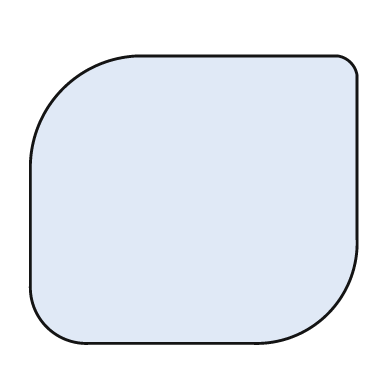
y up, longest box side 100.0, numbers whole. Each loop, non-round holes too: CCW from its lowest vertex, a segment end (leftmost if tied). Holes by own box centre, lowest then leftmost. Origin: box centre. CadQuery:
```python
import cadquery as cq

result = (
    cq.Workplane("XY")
    .moveTo(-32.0, -44.0)
    .lineTo(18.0, -44.0)
    .threePointArc((41.0, -35.0), (50.0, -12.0))
    .lineTo(50.0, 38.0)
    .threePointArc((48.0, 42.0), (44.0, 44.0))
    .lineTo(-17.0, 44.0)
    .threePointArc((-40.0, 34.0), (-50.0, 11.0))
    .lineTo(-50.0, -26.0)
    .threePointArc((-45.0, -39.0), (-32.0, -44.0))
    .close()
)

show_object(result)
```